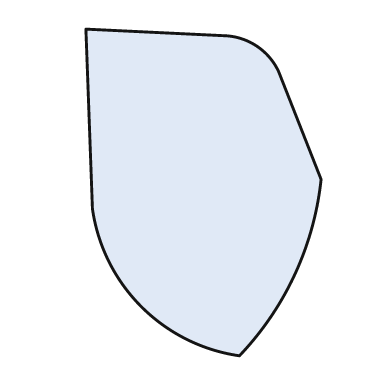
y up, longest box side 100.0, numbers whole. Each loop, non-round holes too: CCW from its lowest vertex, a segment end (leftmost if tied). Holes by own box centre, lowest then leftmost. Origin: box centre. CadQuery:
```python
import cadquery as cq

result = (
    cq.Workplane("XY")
    .moveTo(11.0, -50.0)
    .threePointArc((28.0, -25.0), (36.0, 4.0))
    .lineTo(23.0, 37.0)
    .threePointArc((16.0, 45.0), (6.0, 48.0))
    .lineTo(-36.0, 50.0)
    .lineTo(-34.0, -5.0)
    .threePointArc((-19.0, -35.0), (11.0, -50.0))
    .close()
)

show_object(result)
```